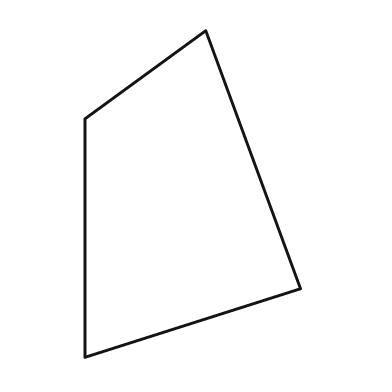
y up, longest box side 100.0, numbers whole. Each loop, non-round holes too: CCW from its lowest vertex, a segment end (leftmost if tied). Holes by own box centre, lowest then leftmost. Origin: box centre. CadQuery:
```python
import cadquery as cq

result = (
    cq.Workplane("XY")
    .moveTo(-33.0, -50.0)
    .lineTo(33.0, -29.0)
    .lineTo(4.0, 50.0)
    .lineTo(-33.0, 23.0)
    .close()
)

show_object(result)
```